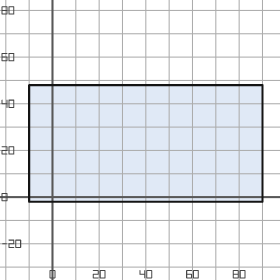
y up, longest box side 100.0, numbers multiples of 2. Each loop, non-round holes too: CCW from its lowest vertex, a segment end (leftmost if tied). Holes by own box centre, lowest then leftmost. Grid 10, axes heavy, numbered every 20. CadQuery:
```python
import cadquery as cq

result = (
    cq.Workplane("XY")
    .moveTo(-10.0, -2.0)
    .lineTo(90.0, -2.0)
    .lineTo(90.0, 48.0)
    .lineTo(-10.0, 48.0)
    .close()
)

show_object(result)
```